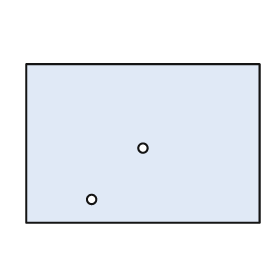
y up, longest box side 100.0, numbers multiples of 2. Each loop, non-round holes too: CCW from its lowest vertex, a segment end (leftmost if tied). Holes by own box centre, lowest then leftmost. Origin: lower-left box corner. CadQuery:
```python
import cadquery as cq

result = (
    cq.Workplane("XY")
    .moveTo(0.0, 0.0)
    .lineTo(100.0, 0.0)
    .lineTo(100.0, 68.0)
    .lineTo(0.0, 68.0)
    .close()
    .moveTo(28.0, 10.0)
    .circle(2.0)
    .moveTo(50.0, 32.0)
    .circle(2.0)
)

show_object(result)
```